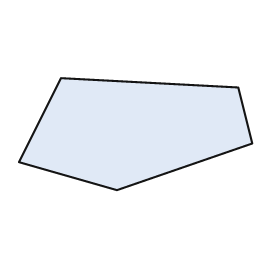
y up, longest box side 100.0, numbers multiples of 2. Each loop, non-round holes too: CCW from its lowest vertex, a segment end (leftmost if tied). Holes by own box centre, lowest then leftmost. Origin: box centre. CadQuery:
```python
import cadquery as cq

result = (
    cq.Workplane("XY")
    .moveTo(-8.0, -24.0)
    .lineTo(50.0, -4.0)
    .lineTo(44.0, 20.0)
    .lineTo(-32.0, 24.0)
    .lineTo(-50.0, -12.0)
    .close()
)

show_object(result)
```